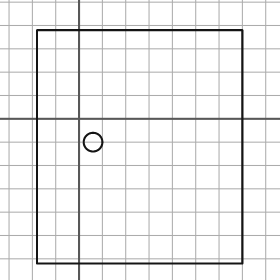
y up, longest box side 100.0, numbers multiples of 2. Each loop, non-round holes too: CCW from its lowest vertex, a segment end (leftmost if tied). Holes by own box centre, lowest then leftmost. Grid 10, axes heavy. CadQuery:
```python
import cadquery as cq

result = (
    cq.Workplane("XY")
    .moveTo(-18.0, -62.0)
    .lineTo(70.0, -62.0)
    .lineTo(70.0, 38.0)
    .lineTo(-18.0, 38.0)
    .close()
    .moveTo(6.0, -10.0)
    .circle(4.0)
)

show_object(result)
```